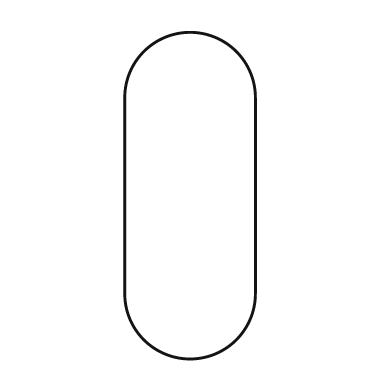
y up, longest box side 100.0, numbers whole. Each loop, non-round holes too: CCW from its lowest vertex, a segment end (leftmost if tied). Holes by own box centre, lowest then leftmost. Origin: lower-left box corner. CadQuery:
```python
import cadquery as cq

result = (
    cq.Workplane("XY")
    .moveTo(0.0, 20.0)
    .threePointArc((20.0, 0.0), (40.0, 20.0))
    .lineTo(40.0, 80.0)
    .threePointArc((20.0, 100.0), (0.0, 80.0))
    .close()
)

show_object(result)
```